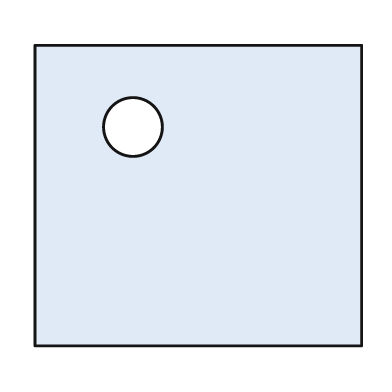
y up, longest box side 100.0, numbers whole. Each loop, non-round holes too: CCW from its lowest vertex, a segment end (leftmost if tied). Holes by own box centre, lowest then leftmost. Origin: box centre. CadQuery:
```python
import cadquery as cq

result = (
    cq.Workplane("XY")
    .moveTo(-50.0, -46.0)
    .lineTo(50.0, -46.0)
    .lineTo(50.0, 46.0)
    .lineTo(-50.0, 46.0)
    .close()
    .moveTo(-20.0, 21.0)
    .circle(9.0)
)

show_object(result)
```